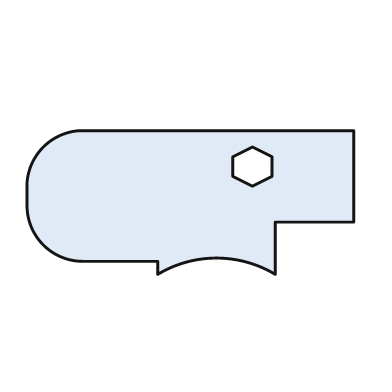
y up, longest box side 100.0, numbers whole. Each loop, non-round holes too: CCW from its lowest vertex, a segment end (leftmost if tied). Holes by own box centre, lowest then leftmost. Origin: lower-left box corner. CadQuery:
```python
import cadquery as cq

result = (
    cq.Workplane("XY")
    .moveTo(40.0, 0.0)
    .threePointArc((58.0, 5.0), (76.0, 0.0))
    .lineTo(76.0, 16.0)
    .lineTo(100.0, 16.0)
    .lineTo(100.0, 44.0)
    .lineTo(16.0, 44.0)
    .threePointArc((5.0, 39.0), (0.0, 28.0))
    .lineTo(0.0, 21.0)
    .threePointArc((5.0, 9.0), (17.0, 4.0))
    .lineTo(40.0, 4.0)
    .close()
    .moveTo(69.0, 27.0)
    .lineTo(75.0, 30.0)
    .lineTo(75.0, 36.0)
    .lineTo(69.0, 39.0)
    .lineTo(63.0, 36.0)
    .lineTo(63.0, 30.0)
    .close()
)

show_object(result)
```